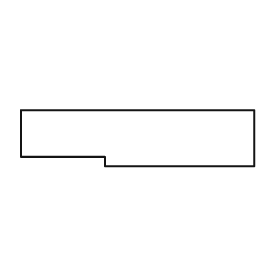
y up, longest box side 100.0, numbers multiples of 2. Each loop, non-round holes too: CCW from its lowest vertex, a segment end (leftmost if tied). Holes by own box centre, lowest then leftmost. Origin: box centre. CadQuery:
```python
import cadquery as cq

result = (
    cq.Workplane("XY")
    .moveTo(-14.0, -12.0)
    .lineTo(50.0, -12.0)
    .lineTo(50.0, 12.0)
    .lineTo(-50.0, 12.0)
    .lineTo(-50.0, -8.0)
    .lineTo(-14.0, -8.0)
    .close()
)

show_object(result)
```